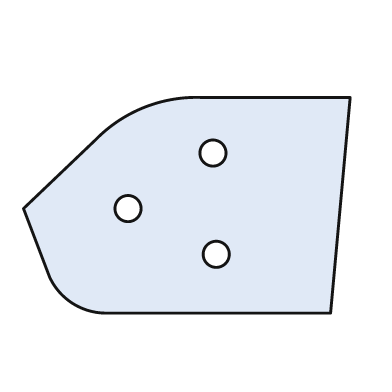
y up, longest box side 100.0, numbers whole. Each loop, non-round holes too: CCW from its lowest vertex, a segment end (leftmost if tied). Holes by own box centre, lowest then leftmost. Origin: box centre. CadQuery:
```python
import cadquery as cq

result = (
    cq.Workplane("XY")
    .moveTo(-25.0, -33.0)
    .lineTo(44.0, -33.0)
    .lineTo(50.0, 33.0)
    .lineTo(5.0, 33.0)
    .threePointArc((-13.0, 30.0), (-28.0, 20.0))
    .lineTo(-50.0, -1.0)
    .lineTo(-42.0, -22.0)
    .threePointArc((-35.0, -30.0), (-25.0, -33.0))
    .close()
    .moveTo(9.0, -15.0)
    .circle(4.0)
    .moveTo(-18.0, -1.0)
    .circle(4.0)
    .moveTo(8.0, 16.0)
    .circle(4.0)
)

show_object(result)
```